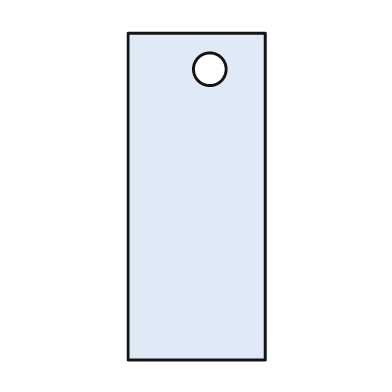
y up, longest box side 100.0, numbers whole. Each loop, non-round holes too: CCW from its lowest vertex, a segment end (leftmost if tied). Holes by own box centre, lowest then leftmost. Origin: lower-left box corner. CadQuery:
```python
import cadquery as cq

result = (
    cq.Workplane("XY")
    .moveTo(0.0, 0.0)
    .lineTo(42.0, 0.0)
    .lineTo(42.0, 100.0)
    .lineTo(0.0, 100.0)
    .close()
    .moveTo(25.0, 89.0)
    .circle(5.0)
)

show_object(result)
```